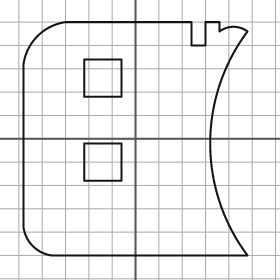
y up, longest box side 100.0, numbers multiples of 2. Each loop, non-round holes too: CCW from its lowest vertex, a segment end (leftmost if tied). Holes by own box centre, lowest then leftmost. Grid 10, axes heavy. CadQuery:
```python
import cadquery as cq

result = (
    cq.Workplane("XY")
    .moveTo(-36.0, -50.0)
    .lineTo(48.0, -50.0)
    .threePointArc((32.0, -2.0), (48.0, 46.0))
    .threePointArc((42.0, 48.0), (36.0, 46.0))
    .lineTo(36.0, 50.0)
    .lineTo(30.0, 50.0)
    .lineTo(30.0, 40.0)
    .lineTo(24.0, 40.0)
    .lineTo(24.0, 50.0)
    .lineTo(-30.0, 50.0)
    .threePointArc((-42.0, 44.0), (-48.0, 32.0))
    .lineTo(-48.0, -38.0)
    .threePointArc((-44.0, -46.0), (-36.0, -50.0))
    .close()
    .moveTo(-22.0, -18.0)
    .lineTo(-6.0, -18.0)
    .lineTo(-6.0, -2.0)
    .lineTo(-22.0, -2.0)
    .close()
    .moveTo(-22.0, 18.0)
    .lineTo(-6.0, 18.0)
    .lineTo(-6.0, 34.0)
    .lineTo(-22.0, 34.0)
    .close()
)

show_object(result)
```